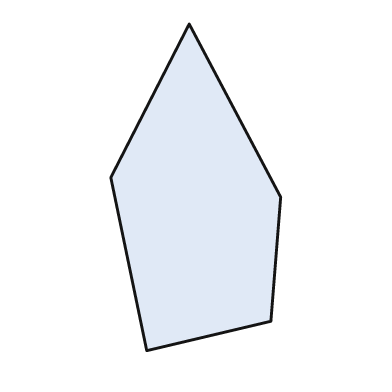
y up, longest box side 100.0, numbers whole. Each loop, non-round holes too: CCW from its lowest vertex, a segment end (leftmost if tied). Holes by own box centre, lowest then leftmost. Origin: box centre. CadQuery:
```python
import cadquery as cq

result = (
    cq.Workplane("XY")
    .moveTo(-15.0, -50.0)
    .lineTo(23.0, -41.0)
    .lineTo(26.0, -3.0)
    .lineTo(-2.0, 50.0)
    .lineTo(-26.0, 3.0)
    .close()
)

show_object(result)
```